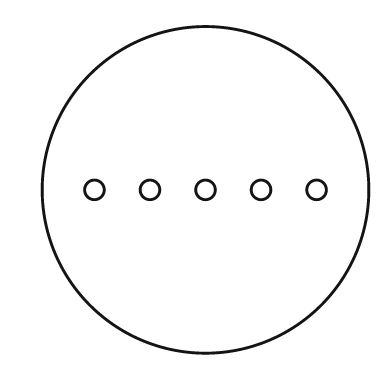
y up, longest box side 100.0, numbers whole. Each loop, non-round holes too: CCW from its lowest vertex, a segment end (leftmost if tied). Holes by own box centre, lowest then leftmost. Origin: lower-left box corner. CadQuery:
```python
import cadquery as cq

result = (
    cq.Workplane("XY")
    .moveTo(50.0, 50.0)
    .circle(50.0)
    .moveTo(16.0, 50.0)
    .circle(3.0)
    .moveTo(33.0, 50.0)
    .circle(3.0)
    .moveTo(50.0, 50.0)
    .circle(3.0)
    .moveTo(67.0, 50.0)
    .circle(3.0)
    .moveTo(84.0, 50.0)
    .circle(3.0)
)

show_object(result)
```